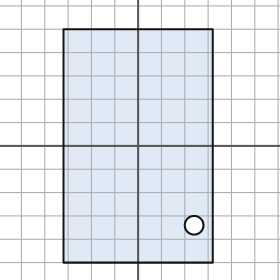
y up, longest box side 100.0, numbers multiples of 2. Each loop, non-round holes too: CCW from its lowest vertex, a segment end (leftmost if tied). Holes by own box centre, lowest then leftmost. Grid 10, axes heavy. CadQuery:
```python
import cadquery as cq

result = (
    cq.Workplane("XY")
    .moveTo(-32.0, -50.0)
    .lineTo(32.0, -50.0)
    .lineTo(32.0, 50.0)
    .lineTo(-32.0, 50.0)
    .close()
    .moveTo(24.0, -34.0)
    .circle(4.0)
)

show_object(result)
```